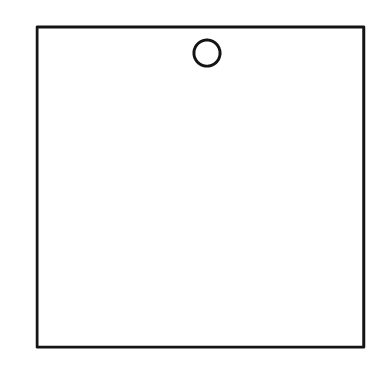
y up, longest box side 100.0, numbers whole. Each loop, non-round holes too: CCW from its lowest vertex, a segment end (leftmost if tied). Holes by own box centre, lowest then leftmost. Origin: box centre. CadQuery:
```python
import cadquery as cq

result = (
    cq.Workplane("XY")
    .moveTo(-50.0, -49.0)
    .lineTo(50.0, -49.0)
    .lineTo(50.0, 49.0)
    .lineTo(-50.0, 49.0)
    .close()
    .moveTo(2.0, 41.0)
    .circle(4.0)
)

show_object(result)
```